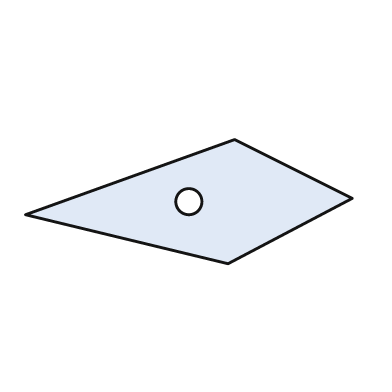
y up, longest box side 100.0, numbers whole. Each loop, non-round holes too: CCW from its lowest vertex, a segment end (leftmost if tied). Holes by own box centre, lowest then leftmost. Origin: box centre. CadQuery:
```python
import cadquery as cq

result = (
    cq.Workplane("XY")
    .moveTo(12.0, -19.0)
    .lineTo(50.0, 1.0)
    .lineTo(14.0, 19.0)
    .lineTo(-50.0, -4.0)
    .close()
    .moveTo(0.0, 0.0)
    .circle(4.0)
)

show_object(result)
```